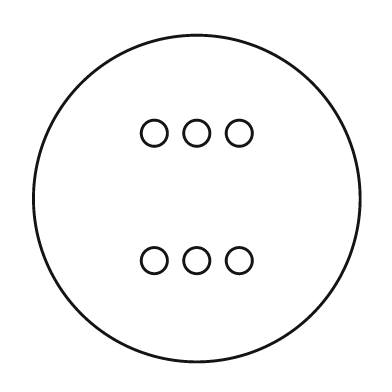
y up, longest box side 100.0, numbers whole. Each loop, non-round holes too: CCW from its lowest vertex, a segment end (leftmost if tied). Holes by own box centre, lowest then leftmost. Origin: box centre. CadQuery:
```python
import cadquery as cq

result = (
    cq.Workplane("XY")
    .moveTo(0.0, 0.0)
    .circle(50.0)
    .moveTo(-13.0, -19.0)
    .circle(4.0)
    .moveTo(0.0, -19.0)
    .circle(4.0)
    .moveTo(13.0, -19.0)
    .circle(4.0)
    .moveTo(-13.0, 20.0)
    .circle(4.0)
    .moveTo(0.0, 20.0)
    .circle(4.0)
    .moveTo(13.0, 20.0)
    .circle(4.0)
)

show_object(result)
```